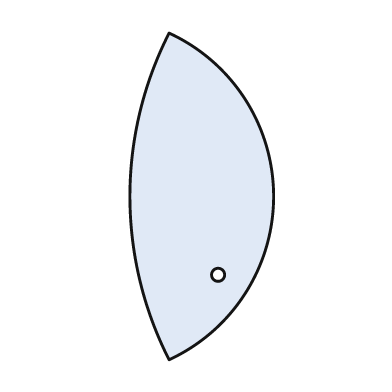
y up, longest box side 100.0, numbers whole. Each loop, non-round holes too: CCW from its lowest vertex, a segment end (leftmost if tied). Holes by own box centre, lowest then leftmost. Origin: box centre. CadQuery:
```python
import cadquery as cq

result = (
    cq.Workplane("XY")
    .moveTo(-10.0, -50.0)
    .threePointArc((22.0, 0.0), (-10.0, 50.0))
    .threePointArc((-22.0, 0.0), (-10.0, -50.0))
    .close()
    .moveTo(5.0, -24.0)
    .circle(2.0)
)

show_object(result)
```